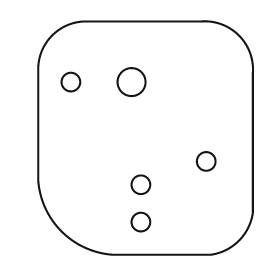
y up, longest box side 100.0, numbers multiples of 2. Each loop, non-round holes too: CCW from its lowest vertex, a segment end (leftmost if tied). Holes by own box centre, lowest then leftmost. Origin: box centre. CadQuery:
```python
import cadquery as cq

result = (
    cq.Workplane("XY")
    .moveTo(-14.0, -50.0)
    .lineTo(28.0, -50.0)
    .threePointArc((40.0, -44.0), (46.0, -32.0))
    .lineTo(46.0, 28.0)
    .threePointArc((40.0, 44.0), (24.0, 50.0))
    .lineTo(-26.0, 50.0)
    .threePointArc((-40.0, 44.0), (-46.0, 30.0))
    .lineTo(-46.0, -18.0)
    .threePointArc((-36.0, -40.0), (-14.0, -50.0))
    .close()
    .moveTo(-2.0, -36.0)
    .circle(4.0)
    .moveTo(-2.0, -20.0)
    .circle(4.0)
    .moveTo(26.0, -10.0)
    .circle(4.0)
    .moveTo(-32.0, 24.0)
    .circle(4.0)
    .moveTo(-6.0, 24.0)
    .circle(6.0)
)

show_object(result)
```